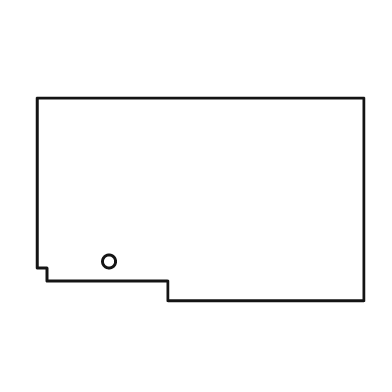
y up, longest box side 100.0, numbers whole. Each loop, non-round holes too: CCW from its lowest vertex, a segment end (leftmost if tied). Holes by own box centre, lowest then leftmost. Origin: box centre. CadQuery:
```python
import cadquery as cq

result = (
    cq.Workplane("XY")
    .moveTo(-10.0, -31.0)
    .lineTo(50.0, -31.0)
    .lineTo(50.0, 31.0)
    .lineTo(-50.0, 31.0)
    .lineTo(-50.0, -21.0)
    .lineTo(-47.0, -21.0)
    .lineTo(-47.0, -25.0)
    .lineTo(-10.0, -25.0)
    .close()
    .moveTo(-28.0, -19.0)
    .circle(2.0)
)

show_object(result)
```